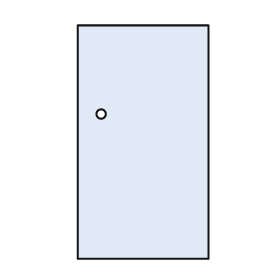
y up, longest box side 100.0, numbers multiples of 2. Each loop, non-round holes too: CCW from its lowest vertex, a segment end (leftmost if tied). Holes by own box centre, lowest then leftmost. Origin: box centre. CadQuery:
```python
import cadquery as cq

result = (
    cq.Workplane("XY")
    .moveTo(-28.0, -50.0)
    .lineTo(28.0, -50.0)
    .lineTo(28.0, 50.0)
    .lineTo(-28.0, 50.0)
    .close()
    .moveTo(-18.0, 12.0)
    .circle(2.0)
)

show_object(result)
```